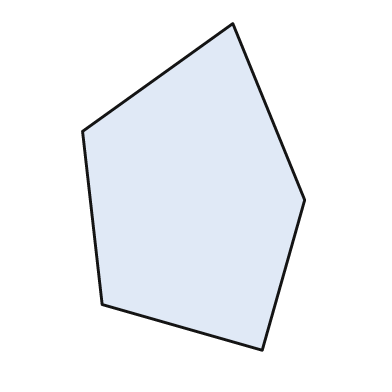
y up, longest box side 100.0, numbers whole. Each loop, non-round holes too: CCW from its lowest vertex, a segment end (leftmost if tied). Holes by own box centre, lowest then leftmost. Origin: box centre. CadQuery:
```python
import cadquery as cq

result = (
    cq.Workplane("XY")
    .moveTo(21.0, -50.0)
    .lineTo(34.0, -4.0)
    .lineTo(12.0, 50.0)
    .lineTo(-34.0, 17.0)
    .lineTo(-28.0, -36.0)
    .close()
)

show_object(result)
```